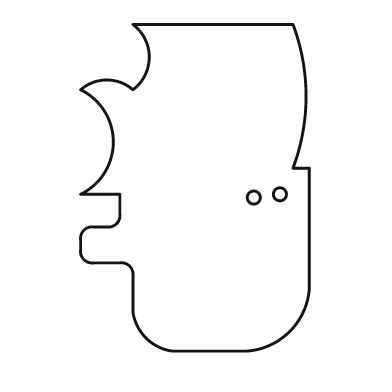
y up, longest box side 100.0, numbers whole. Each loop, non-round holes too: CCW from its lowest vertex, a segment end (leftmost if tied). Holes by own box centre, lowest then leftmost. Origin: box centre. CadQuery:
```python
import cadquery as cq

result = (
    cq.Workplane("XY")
    .moveTo(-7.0, -50.0)
    .lineTo(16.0, -50.0)
    .threePointArc((29.0, -44.0), (35.0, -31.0))
    .lineTo(35.0, 6.0)
    .lineTo(30.0, 6.0)
    .threePointArc((34.0, 28.0), (30.0, 50.0))
    .lineTo(-19.0, 50.0)
    .threePointArc((-14.0, 40.0), (-19.0, 30.0))
    .threePointArc((-27.0, 33.0), (-35.0, 30.0))
    .threePointArc((-25.0, 14.0), (-35.0, -2.0))
    .lineTo(-23.0, -2.0)
    .lineTo(-23.0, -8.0)
    .threePointArc((-24.0, -11.0), (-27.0, -12.0))
    .lineTo(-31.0, -12.0)
    .threePointArc((-34.0, -13.0), (-35.0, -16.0))
    .lineTo(-35.0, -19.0)
    .threePointArc((-34.0, -22.0), (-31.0, -23.0))
    .lineTo(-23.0, -23.0)
    .threePointArc((-20.0, -24.0), (-19.0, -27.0))
    .lineTo(-19.0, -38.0)
    .threePointArc((-15.0, -46.0), (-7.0, -50.0))
    .close()
    .moveTo(18.0, -3.0)
    .circle(2.0)
    .moveTo(26.0, -2.0)
    .circle(2.0)
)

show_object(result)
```